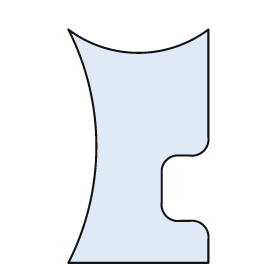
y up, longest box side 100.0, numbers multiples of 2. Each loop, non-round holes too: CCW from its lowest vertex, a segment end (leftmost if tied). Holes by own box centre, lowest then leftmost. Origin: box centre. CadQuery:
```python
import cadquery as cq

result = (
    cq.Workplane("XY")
    .moveTo(-30.0, -50.0)
    .lineTo(30.0, -50.0)
    .lineTo(30.0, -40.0)
    .threePointArc((28.0, -34.0), (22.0, -32.0))
    .lineTo(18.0, -32.0)
    .threePointArc((12.0, -30.0), (10.0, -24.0))
    .lineTo(10.0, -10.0)
    .threePointArc((12.0, -6.0), (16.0, -4.0))
    .lineTo(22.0, -4.0)
    .threePointArc((28.0, -2.0), (30.0, 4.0))
    .lineTo(30.0, 50.0)
    .threePointArc((0.0, 40.0), (-30.0, 50.0))
    .threePointArc((-18.0, 0.0), (-30.0, -50.0))
    .close()
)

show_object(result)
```